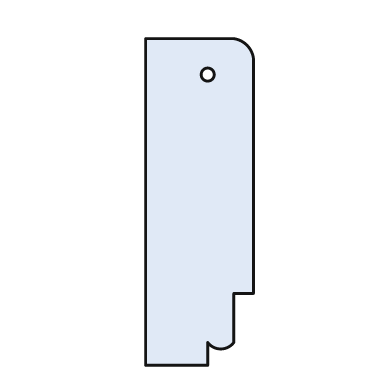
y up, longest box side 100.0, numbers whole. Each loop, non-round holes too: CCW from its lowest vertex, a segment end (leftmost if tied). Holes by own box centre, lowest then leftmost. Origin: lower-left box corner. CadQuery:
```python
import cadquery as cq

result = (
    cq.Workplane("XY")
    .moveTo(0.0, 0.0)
    .lineTo(19.0, 0.0)
    .lineTo(19.0, 7.0)
    .threePointArc((23.0, 5.0), (27.0, 7.0))
    .lineTo(27.0, 22.0)
    .lineTo(33.0, 22.0)
    .lineTo(33.0, 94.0)
    .threePointArc((31.0, 98.0), (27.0, 100.0))
    .lineTo(0.0, 100.0)
    .close()
    .moveTo(19.0, 89.0)
    .circle(2.0)
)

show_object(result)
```